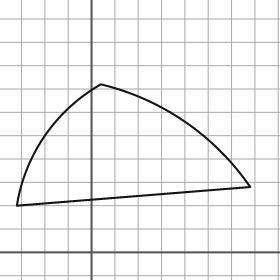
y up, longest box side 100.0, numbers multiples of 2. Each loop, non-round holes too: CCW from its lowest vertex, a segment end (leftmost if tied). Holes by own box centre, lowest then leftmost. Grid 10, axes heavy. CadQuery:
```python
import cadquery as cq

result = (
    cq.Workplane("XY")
    .moveTo(-32.0, 20.0)
    .lineTo(68.0, 28.0)
    .threePointArc((40.0, 56.0), (4.0, 72.0))
    .threePointArc((-20.0, 50.0), (-32.0, 20.0))
    .close()
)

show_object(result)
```